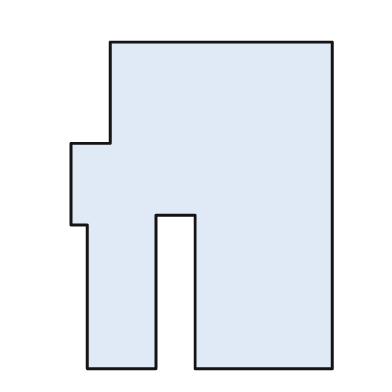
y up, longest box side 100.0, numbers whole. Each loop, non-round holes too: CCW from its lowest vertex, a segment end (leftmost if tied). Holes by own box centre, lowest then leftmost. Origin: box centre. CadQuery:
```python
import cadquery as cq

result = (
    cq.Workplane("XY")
    .moveTo(-35.0, -50.0)
    .lineTo(-14.0, -50.0)
    .lineTo(-14.0, -3.0)
    .lineTo(-2.0, -3.0)
    .lineTo(-2.0, -50.0)
    .lineTo(40.0, -50.0)
    .lineTo(40.0, 50.0)
    .lineTo(-28.0, 50.0)
    .lineTo(-28.0, 19.0)
    .lineTo(-40.0, 19.0)
    .lineTo(-40.0, -6.0)
    .lineTo(-35.0, -6.0)
    .close()
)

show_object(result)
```